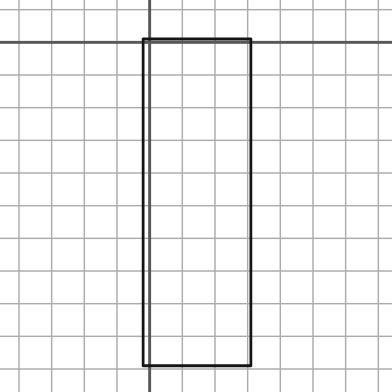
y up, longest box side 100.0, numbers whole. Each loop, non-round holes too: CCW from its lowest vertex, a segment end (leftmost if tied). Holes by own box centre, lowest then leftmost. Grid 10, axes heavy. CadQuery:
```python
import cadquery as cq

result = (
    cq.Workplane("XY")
    .moveTo(-2.0, -99.0)
    .lineTo(31.0, -99.0)
    .lineTo(31.0, 1.0)
    .lineTo(-2.0, 1.0)
    .close()
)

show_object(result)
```